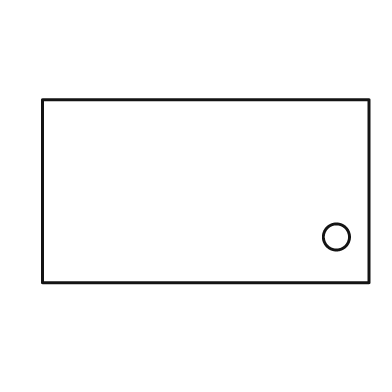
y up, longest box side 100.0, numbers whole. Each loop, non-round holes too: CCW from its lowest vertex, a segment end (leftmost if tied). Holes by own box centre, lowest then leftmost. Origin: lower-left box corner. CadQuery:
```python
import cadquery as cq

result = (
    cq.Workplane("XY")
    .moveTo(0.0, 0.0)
    .lineTo(100.0, 0.0)
    .lineTo(100.0, 56.0)
    .lineTo(0.0, 56.0)
    .close()
    .moveTo(90.0, 14.0)
    .circle(4.0)
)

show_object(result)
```